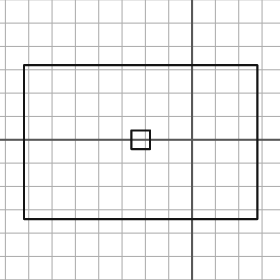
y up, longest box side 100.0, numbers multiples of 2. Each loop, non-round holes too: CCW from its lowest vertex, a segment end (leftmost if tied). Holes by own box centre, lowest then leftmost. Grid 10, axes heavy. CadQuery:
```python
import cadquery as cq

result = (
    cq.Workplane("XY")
    .moveTo(-72.0, -34.0)
    .lineTo(28.0, -34.0)
    .lineTo(28.0, 32.0)
    .lineTo(-72.0, 32.0)
    .close()
    .moveTo(-26.0, -4.0)
    .lineTo(-18.0, -4.0)
    .lineTo(-18.0, 4.0)
    .lineTo(-26.0, 4.0)
    .close()
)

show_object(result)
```